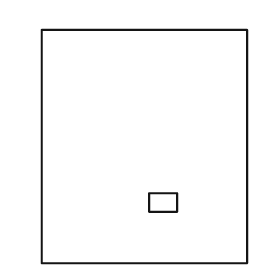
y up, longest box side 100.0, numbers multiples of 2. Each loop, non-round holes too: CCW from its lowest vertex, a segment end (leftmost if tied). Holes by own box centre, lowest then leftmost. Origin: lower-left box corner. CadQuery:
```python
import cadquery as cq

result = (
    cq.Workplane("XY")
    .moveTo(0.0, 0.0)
    .lineTo(88.0, 0.0)
    .lineTo(88.0, 100.0)
    .lineTo(0.0, 100.0)
    .close()
    .moveTo(46.0, 22.0)
    .lineTo(58.0, 22.0)
    .lineTo(58.0, 30.0)
    .lineTo(46.0, 30.0)
    .close()
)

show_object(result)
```